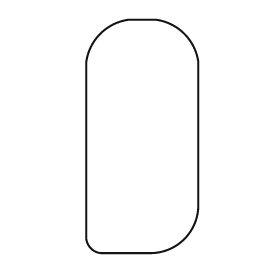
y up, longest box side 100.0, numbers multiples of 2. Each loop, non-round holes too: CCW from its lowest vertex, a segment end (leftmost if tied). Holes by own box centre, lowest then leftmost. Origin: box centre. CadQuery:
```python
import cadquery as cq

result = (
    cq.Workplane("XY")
    .moveTo(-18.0, -50.0)
    .lineTo(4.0, -50.0)
    .threePointArc((18.0, -44.0), (24.0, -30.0))
    .lineTo(24.0, 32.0)
    .threePointArc((18.0, 44.0), (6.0, 50.0))
    .lineTo(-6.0, 50.0)
    .threePointArc((-18.0, 44.0), (-24.0, 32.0))
    .lineTo(-24.0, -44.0)
    .threePointArc((-22.0, -48.0), (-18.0, -50.0))
    .close()
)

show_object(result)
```